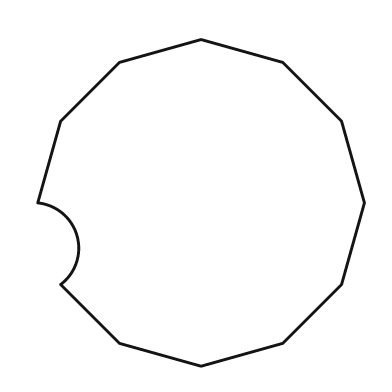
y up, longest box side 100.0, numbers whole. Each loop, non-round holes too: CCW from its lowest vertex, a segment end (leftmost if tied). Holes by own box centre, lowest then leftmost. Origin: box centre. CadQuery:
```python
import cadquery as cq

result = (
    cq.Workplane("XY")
    .moveTo(0.0, -50.0)
    .lineTo(25.0, -43.0)
    .lineTo(43.0, -25.0)
    .lineTo(50.0, 0.0)
    .lineTo(43.0, 25.0)
    .lineTo(25.0, 43.0)
    .lineTo(0.0, 50.0)
    .lineTo(-25.0, 43.0)
    .lineTo(-43.0, 25.0)
    .lineTo(-50.0, 0.0)
    .threePointArc((-38.0, -10.0), (-43.0, -25.0))
    .lineTo(-25.0, -43.0)
    .close()
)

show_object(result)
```